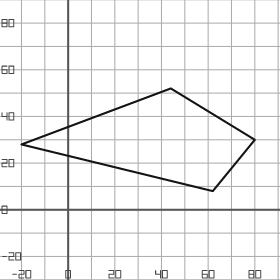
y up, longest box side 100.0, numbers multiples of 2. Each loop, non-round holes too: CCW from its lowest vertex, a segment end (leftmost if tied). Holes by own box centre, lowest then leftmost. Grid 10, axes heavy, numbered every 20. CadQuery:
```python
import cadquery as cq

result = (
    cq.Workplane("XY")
    .moveTo(62.0, 8.0)
    .lineTo(80.0, 30.0)
    .lineTo(44.0, 52.0)
    .lineTo(-20.0, 28.0)
    .close()
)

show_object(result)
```